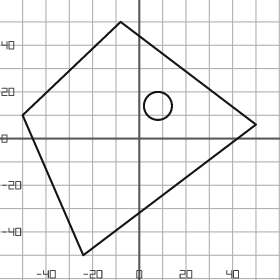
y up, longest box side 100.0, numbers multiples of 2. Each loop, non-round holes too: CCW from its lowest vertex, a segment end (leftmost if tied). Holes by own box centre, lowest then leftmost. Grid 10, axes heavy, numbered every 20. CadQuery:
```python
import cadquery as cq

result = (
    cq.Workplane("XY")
    .moveTo(-24.0, -50.0)
    .lineTo(50.0, 6.0)
    .lineTo(-8.0, 50.0)
    .lineTo(-50.0, 10.0)
    .close()
    .moveTo(8.0, 14.0)
    .circle(6.0)
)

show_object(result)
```